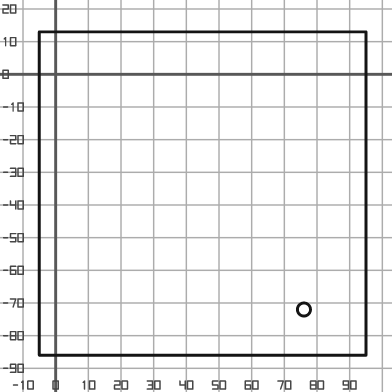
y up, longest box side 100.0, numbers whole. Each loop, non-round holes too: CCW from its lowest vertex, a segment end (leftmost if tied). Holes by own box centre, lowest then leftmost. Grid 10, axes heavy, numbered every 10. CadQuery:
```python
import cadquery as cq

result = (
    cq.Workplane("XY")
    .moveTo(-5.0, -86.0)
    .lineTo(95.0, -86.0)
    .lineTo(95.0, 13.0)
    .lineTo(-5.0, 13.0)
    .close()
    .moveTo(76.0, -72.0)
    .circle(2.0)
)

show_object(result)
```